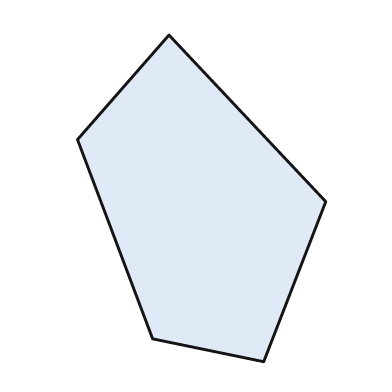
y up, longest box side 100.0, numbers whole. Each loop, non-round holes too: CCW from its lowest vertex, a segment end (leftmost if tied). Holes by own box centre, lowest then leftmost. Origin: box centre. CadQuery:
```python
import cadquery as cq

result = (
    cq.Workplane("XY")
    .moveTo(19.0, -50.0)
    .lineTo(38.0, -1.0)
    .lineTo(-10.0, 50.0)
    .lineTo(-38.0, 18.0)
    .lineTo(-15.0, -43.0)
    .close()
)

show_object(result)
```